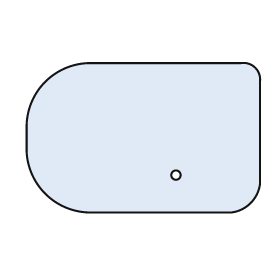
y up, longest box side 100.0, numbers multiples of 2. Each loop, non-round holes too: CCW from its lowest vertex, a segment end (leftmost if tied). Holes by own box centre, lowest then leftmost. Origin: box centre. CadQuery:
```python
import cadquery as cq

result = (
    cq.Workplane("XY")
    .moveTo(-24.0, -32.0)
    .lineTo(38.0, -32.0)
    .threePointArc((46.0, -28.0), (50.0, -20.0))
    .lineTo(50.0, 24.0)
    .threePointArc((48.0, 30.0), (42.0, 32.0))
    .lineTo(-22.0, 32.0)
    .threePointArc((-42.0, 24.0), (-50.0, 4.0))
    .lineTo(-50.0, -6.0)
    .threePointArc((-42.0, -24.0), (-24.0, -32.0))
    .close()
    .moveTo(14.0, -16.0)
    .circle(2.0)
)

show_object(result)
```